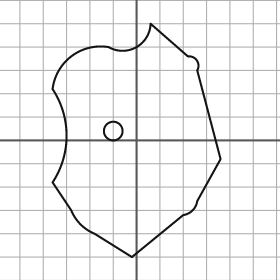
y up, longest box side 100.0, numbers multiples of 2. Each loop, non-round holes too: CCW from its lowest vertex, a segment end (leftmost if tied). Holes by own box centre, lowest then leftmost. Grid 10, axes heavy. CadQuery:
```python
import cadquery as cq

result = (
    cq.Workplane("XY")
    .moveTo(-2.0, -50.0)
    .lineTo(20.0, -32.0)
    .threePointArc((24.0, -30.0), (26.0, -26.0))
    .lineTo(36.0, -8.0)
    .lineTo(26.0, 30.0)
    .threePointArc((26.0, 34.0), (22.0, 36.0))
    .lineTo(6.0, 50.0)
    .threePointArc((0.0, 40.0), (-12.0, 40.0))
    .threePointArc((-28.0, 36.0), (-36.0, 22.0))
    .threePointArc((-30.0, 2.0), (-36.0, -18.0))
    .lineTo(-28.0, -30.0)
    .threePointArc((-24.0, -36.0), (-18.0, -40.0))
    .close()
    .moveTo(-10.0, 4.0)
    .circle(4.0)
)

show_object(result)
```